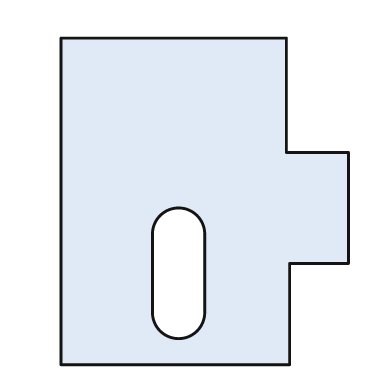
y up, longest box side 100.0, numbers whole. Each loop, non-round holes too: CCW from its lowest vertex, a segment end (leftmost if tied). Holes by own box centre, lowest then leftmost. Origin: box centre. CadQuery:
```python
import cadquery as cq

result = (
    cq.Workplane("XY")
    .moveTo(-44.0, -50.0)
    .lineTo(26.0, -50.0)
    .lineTo(26.0, -19.0)
    .lineTo(44.0, -19.0)
    .lineTo(44.0, 15.0)
    .lineTo(25.0, 15.0)
    .lineTo(25.0, 50.0)
    .lineTo(-44.0, 50.0)
    .close()
    .moveTo(-16.0, -34.0)
    .threePointArc((-8.0, -42.0), (0.0, -34.0))
    .lineTo(0.0, -10.0)
    .threePointArc((-8.0, -2.0), (-16.0, -10.0))
    .close()
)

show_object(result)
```